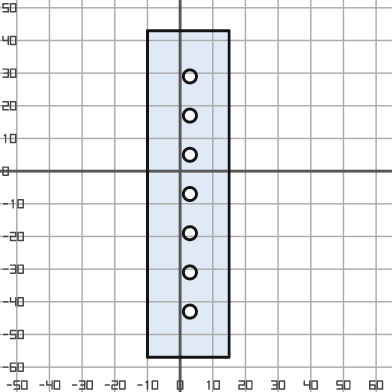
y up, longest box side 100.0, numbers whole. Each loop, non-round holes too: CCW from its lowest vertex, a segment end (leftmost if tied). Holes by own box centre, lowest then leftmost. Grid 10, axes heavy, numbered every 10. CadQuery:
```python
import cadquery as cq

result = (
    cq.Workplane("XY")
    .moveTo(-10.0, -57.0)
    .lineTo(15.0, -57.0)
    .lineTo(15.0, 43.0)
    .lineTo(-10.0, 43.0)
    .close()
    .moveTo(3.0, -43.0)
    .circle(2.0)
    .moveTo(3.0, -31.0)
    .circle(2.0)
    .moveTo(3.0, -19.0)
    .circle(2.0)
    .moveTo(3.0, -7.0)
    .circle(2.0)
    .moveTo(3.0, 5.0)
    .circle(2.0)
    .moveTo(3.0, 17.0)
    .circle(2.0)
    .moveTo(3.0, 29.0)
    .circle(2.0)
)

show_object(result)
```